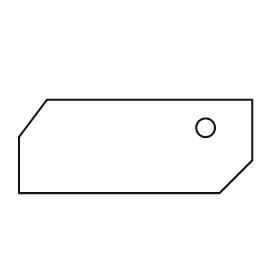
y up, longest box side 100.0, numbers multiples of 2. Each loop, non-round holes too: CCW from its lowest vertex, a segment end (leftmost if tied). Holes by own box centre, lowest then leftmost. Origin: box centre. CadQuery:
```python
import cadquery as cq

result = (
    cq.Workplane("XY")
    .moveTo(-50.0, -20.0)
    .lineTo(36.0, -20.0)
    .lineTo(50.0, -6.0)
    .lineTo(50.0, 20.0)
    .lineTo(-38.0, 20.0)
    .lineTo(-50.0, 4.0)
    .close()
    .moveTo(30.0, 8.0)
    .circle(4.0)
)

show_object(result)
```